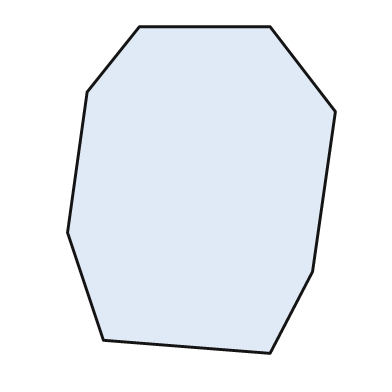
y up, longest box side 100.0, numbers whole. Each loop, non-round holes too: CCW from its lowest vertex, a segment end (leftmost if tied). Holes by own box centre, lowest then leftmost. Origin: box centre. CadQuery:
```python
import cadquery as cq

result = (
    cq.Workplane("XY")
    .moveTo(21.0, -50.0)
    .lineTo(34.0, -25.0)
    .lineTo(41.0, 24.0)
    .lineTo(21.0, 50.0)
    .lineTo(-19.0, 50.0)
    .lineTo(-35.0, 30.0)
    .lineTo(-41.0, -13.0)
    .lineTo(-30.0, -46.0)
    .close()
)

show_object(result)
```